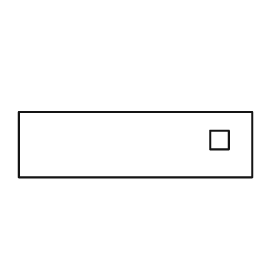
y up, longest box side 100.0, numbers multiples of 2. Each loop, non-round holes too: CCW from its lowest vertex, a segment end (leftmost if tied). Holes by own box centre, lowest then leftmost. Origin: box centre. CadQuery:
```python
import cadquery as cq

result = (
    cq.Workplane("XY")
    .moveTo(-50.0, -14.0)
    .lineTo(50.0, -14.0)
    .lineTo(50.0, 14.0)
    .lineTo(-50.0, 14.0)
    .close()
    .moveTo(32.0, -2.0)
    .lineTo(40.0, -2.0)
    .lineTo(40.0, 6.0)
    .lineTo(32.0, 6.0)
    .close()
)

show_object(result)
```